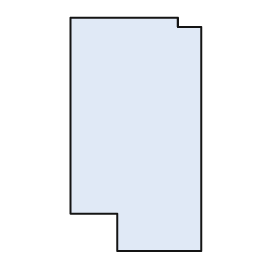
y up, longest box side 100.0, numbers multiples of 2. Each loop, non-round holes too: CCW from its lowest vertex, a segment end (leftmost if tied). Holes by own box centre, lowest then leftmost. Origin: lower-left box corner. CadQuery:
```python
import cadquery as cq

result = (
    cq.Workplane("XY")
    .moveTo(20.0, 0.0)
    .lineTo(56.0, 0.0)
    .lineTo(56.0, 96.0)
    .lineTo(46.0, 96.0)
    .lineTo(46.0, 100.0)
    .lineTo(0.0, 100.0)
    .lineTo(0.0, 16.0)
    .lineTo(20.0, 16.0)
    .close()
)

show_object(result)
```